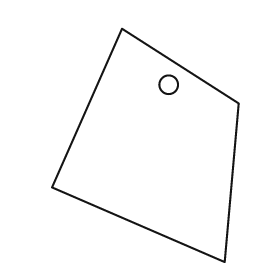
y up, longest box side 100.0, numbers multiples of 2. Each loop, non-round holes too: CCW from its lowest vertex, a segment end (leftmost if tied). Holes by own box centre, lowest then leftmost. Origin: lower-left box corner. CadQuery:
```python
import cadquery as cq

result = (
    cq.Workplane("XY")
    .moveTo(74.0, 0.0)
    .lineTo(80.0, 68.0)
    .lineTo(30.0, 100.0)
    .lineTo(0.0, 32.0)
    .close()
    .moveTo(50.0, 76.0)
    .circle(4.0)
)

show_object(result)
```